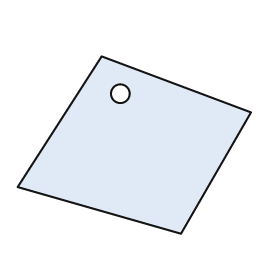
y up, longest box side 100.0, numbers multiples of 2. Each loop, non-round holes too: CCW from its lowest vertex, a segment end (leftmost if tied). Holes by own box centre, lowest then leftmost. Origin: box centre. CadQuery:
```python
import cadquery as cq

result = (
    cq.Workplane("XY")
    .moveTo(20.0, -38.0)
    .lineTo(50.0, 14.0)
    .lineTo(-14.0, 38.0)
    .lineTo(-50.0, -18.0)
    .close()
    .moveTo(-6.0, 22.0)
    .circle(4.0)
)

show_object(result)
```